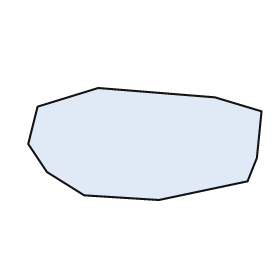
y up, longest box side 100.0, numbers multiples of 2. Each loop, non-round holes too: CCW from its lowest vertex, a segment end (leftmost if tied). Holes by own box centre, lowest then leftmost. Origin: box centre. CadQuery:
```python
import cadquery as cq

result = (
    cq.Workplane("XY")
    .moveTo(6.0, -24.0)
    .lineTo(44.0, -16.0)
    .lineTo(48.0, -6.0)
    .lineTo(50.0, 14.0)
    .lineTo(30.0, 20.0)
    .lineTo(-20.0, 24.0)
    .lineTo(-46.0, 16.0)
    .lineTo(-50.0, 0.0)
    .lineTo(-42.0, -12.0)
    .lineTo(-26.0, -22.0)
    .close()
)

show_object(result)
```